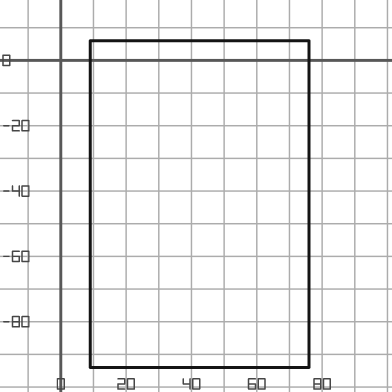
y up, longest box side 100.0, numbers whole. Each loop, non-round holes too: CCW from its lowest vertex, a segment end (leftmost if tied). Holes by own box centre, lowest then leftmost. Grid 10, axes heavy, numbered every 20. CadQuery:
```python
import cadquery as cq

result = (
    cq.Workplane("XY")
    .moveTo(9.0, -94.0)
    .lineTo(76.0, -94.0)
    .lineTo(76.0, 6.0)
    .lineTo(9.0, 6.0)
    .close()
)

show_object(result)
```